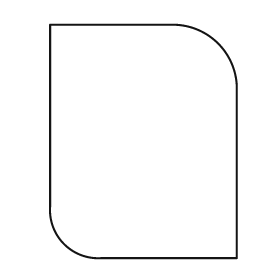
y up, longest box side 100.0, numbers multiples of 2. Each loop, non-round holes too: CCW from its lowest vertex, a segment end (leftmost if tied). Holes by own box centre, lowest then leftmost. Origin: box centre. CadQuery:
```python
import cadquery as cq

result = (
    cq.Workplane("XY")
    .moveTo(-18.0, -50.0)
    .lineTo(40.0, -50.0)
    .lineTo(40.0, 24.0)
    .threePointArc((32.0, 42.0), (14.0, 50.0))
    .lineTo(-40.0, 50.0)
    .lineTo(-40.0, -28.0)
    .threePointArc((-34.0, -44.0), (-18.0, -50.0))
    .close()
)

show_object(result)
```